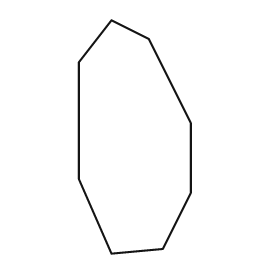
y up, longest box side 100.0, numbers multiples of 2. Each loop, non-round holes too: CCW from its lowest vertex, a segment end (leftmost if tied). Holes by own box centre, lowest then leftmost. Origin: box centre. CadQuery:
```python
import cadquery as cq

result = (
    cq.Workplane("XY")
    .moveTo(-10.0, -50.0)
    .lineTo(12.0, -48.0)
    .lineTo(24.0, -24.0)
    .lineTo(24.0, 6.0)
    .lineTo(6.0, 42.0)
    .lineTo(-10.0, 50.0)
    .lineTo(-24.0, 32.0)
    .lineTo(-24.0, -18.0)
    .close()
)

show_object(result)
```